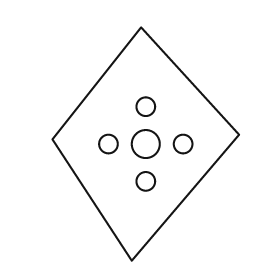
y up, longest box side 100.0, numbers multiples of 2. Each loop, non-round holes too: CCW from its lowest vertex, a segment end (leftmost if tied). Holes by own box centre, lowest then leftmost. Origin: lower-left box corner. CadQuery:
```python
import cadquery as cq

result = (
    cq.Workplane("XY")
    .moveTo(34.0, 0.0)
    .lineTo(80.0, 54.0)
    .lineTo(38.0, 100.0)
    .lineTo(0.0, 52.0)
    .close()
    .moveTo(40.0, 34.0)
    .circle(4.0)
    .moveTo(24.0, 50.0)
    .circle(4.0)
    .moveTo(40.0, 50.0)
    .circle(6.0)
    .moveTo(56.0, 50.0)
    .circle(4.0)
    .moveTo(40.0, 66.0)
    .circle(4.0)
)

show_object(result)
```